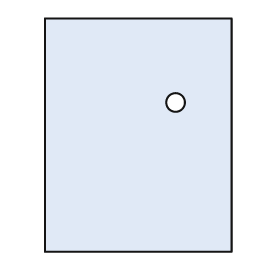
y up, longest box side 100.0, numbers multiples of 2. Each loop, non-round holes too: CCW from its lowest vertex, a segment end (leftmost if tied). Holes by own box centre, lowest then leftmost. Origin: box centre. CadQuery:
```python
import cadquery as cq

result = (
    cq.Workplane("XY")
    .moveTo(-40.0, -50.0)
    .lineTo(40.0, -50.0)
    .lineTo(40.0, 50.0)
    .lineTo(-40.0, 50.0)
    .close()
    .moveTo(16.0, 14.0)
    .circle(4.0)
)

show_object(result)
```